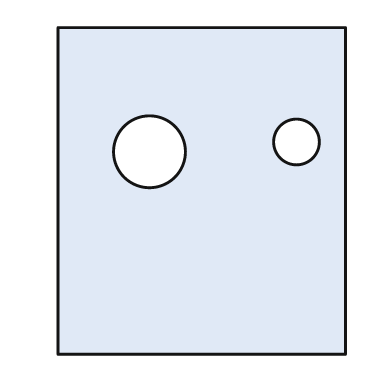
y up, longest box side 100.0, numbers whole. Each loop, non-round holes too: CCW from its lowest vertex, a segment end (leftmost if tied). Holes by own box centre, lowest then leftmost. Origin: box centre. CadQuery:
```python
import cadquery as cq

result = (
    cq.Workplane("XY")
    .moveTo(-44.0, -50.0)
    .lineTo(44.0, -50.0)
    .lineTo(44.0, 50.0)
    .lineTo(-44.0, 50.0)
    .close()
    .moveTo(-16.0, 12.0)
    .circle(11.0)
    .moveTo(29.0, 15.0)
    .circle(7.0)
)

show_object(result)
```